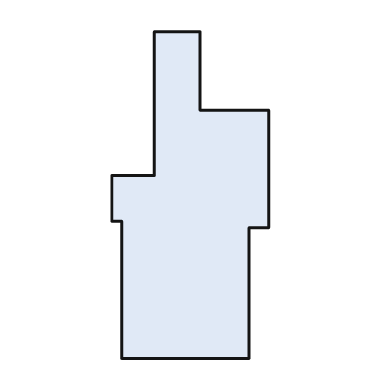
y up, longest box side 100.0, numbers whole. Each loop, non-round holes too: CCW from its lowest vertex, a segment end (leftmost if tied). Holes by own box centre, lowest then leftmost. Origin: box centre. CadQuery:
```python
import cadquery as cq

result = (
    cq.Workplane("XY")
    .moveTo(-21.0, -50.0)
    .lineTo(18.0, -50.0)
    .lineTo(18.0, -10.0)
    .lineTo(24.0, -10.0)
    .lineTo(24.0, 26.0)
    .lineTo(3.0, 26.0)
    .lineTo(3.0, 50.0)
    .lineTo(-11.0, 50.0)
    .lineTo(-11.0, 6.0)
    .lineTo(-24.0, 6.0)
    .lineTo(-24.0, -8.0)
    .lineTo(-21.0, -8.0)
    .close()
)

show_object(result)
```